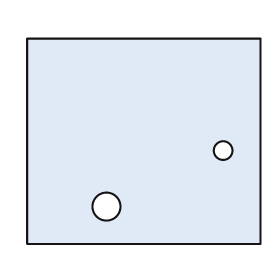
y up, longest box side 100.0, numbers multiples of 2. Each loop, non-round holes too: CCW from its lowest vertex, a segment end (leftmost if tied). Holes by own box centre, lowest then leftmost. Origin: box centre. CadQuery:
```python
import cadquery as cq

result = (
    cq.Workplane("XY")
    .moveTo(-50.0, -44.0)
    .lineTo(50.0, -44.0)
    .lineTo(50.0, 44.0)
    .lineTo(-50.0, 44.0)
    .close()
    .moveTo(-16.0, -28.0)
    .circle(6.0)
    .moveTo(34.0, -4.0)
    .circle(4.0)
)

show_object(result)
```